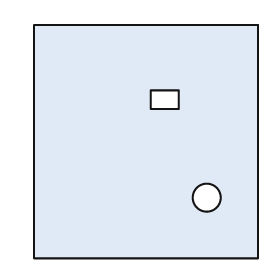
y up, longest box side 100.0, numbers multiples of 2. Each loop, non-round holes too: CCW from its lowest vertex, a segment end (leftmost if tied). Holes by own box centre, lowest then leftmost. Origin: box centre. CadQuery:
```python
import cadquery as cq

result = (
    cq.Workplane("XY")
    .moveTo(-48.0, -50.0)
    .lineTo(48.0, -50.0)
    .lineTo(48.0, 50.0)
    .lineTo(-48.0, 50.0)
    .close()
    .moveTo(26.0, -24.0)
    .circle(6.0)
    .moveTo(2.0, 14.0)
    .lineTo(14.0, 14.0)
    .lineTo(14.0, 22.0)
    .lineTo(2.0, 22.0)
    .close()
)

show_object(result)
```